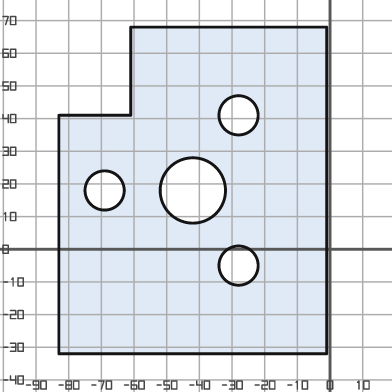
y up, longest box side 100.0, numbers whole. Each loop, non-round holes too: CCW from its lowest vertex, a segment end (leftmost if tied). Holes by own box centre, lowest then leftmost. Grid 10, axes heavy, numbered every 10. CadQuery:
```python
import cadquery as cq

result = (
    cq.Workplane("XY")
    .moveTo(-83.0, -32.0)
    .lineTo(-1.0, -32.0)
    .lineTo(-1.0, 68.0)
    .lineTo(-61.0, 68.0)
    .lineTo(-61.0, 41.0)
    .lineTo(-83.0, 41.0)
    .close()
    .moveTo(-28.0, -5.0)
    .circle(6.0)
    .moveTo(-69.0, 18.0)
    .circle(6.0)
    .moveTo(-42.0, 18.0)
    .circle(10.0)
    .moveTo(-28.0, 41.0)
    .circle(6.0)
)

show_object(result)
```